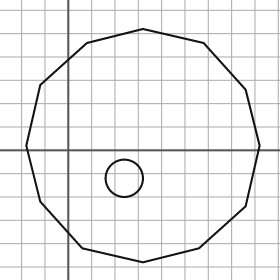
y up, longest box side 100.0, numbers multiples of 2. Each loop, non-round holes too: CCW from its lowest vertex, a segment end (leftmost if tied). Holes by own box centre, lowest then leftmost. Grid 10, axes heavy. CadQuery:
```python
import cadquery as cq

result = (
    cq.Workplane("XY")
    .moveTo(32.0, -48.0)
    .lineTo(56.0, -42.0)
    .lineTo(76.0, -24.0)
    .lineTo(82.0, 2.0)
    .lineTo(76.0, 26.0)
    .lineTo(58.0, 46.0)
    .lineTo(32.0, 52.0)
    .lineTo(8.0, 46.0)
    .lineTo(-12.0, 28.0)
    .lineTo(-18.0, 2.0)
    .lineTo(-12.0, -22.0)
    .lineTo(6.0, -42.0)
    .close()
    .moveTo(24.0, -12.0)
    .circle(8.0)
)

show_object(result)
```